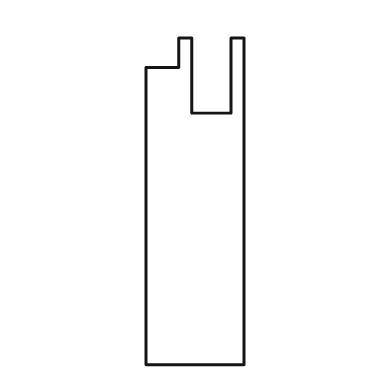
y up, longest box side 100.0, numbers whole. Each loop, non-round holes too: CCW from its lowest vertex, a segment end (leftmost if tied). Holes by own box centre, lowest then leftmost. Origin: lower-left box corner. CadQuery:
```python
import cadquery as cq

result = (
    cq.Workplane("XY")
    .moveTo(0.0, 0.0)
    .lineTo(30.0, 0.0)
    .lineTo(30.0, 100.0)
    .lineTo(26.0, 100.0)
    .lineTo(26.0, 77.0)
    .lineTo(14.0, 77.0)
    .lineTo(14.0, 100.0)
    .lineTo(10.0, 100.0)
    .lineTo(10.0, 91.0)
    .lineTo(0.0, 91.0)
    .close()
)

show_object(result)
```